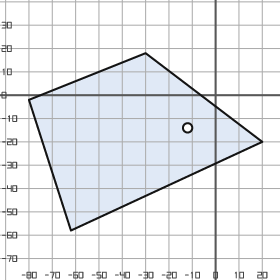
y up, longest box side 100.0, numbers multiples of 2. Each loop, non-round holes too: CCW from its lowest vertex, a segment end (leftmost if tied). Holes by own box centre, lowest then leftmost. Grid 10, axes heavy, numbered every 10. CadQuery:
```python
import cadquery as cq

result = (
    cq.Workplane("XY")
    .moveTo(-62.0, -58.0)
    .lineTo(20.0, -20.0)
    .lineTo(-30.0, 18.0)
    .lineTo(-80.0, -2.0)
    .close()
    .moveTo(-12.0, -14.0)
    .circle(2.0)
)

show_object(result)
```